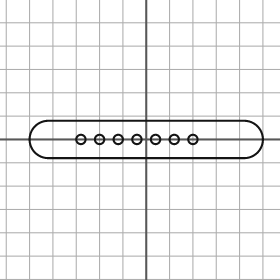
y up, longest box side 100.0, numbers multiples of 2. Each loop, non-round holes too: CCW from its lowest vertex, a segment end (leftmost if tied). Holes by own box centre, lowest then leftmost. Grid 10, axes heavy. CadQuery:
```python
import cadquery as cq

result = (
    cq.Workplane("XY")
    .moveTo(-42.0, -8.0)
    .lineTo(42.0, -8.0)
    .threePointArc((50.0, 0.0), (42.0, 8.0))
    .lineTo(-42.0, 8.0)
    .threePointArc((-50.0, 0.0), (-42.0, -8.0))
    .close()
    .moveTo(-28.0, 0.0)
    .circle(2.0)
    .moveTo(-20.0, 0.0)
    .circle(2.0)
    .moveTo(-12.0, 0.0)
    .circle(2.0)
    .moveTo(-4.0, 0.0)
    .circle(2.0)
    .moveTo(4.0, 0.0)
    .circle(2.0)
    .moveTo(12.0, 0.0)
    .circle(2.0)
    .moveTo(20.0, 0.0)
    .circle(2.0)
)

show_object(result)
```